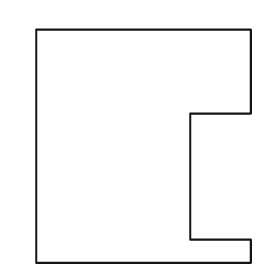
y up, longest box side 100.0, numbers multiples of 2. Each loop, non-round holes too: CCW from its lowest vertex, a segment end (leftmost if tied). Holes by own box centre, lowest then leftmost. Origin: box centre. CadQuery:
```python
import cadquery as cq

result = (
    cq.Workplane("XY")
    .moveTo(-46.0, -50.0)
    .lineTo(46.0, -50.0)
    .lineTo(46.0, -40.0)
    .lineTo(20.0, -40.0)
    .lineTo(20.0, 14.0)
    .lineTo(46.0, 14.0)
    .lineTo(46.0, 50.0)
    .lineTo(-46.0, 50.0)
    .close()
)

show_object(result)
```